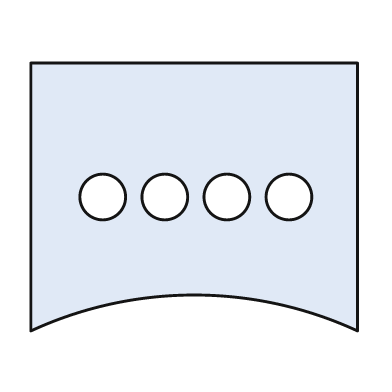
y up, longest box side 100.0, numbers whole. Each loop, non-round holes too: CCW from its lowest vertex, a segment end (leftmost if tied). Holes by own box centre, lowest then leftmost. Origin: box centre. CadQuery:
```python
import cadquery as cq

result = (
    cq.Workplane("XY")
    .moveTo(-50.0, -41.0)
    .threePointArc((0.0, -30.0), (50.0, -41.0))
    .lineTo(50.0, 41.0)
    .lineTo(-50.0, 41.0)
    .close()
    .moveTo(-28.0, 0.0)
    .circle(7.0)
    .moveTo(-9.0, 0.0)
    .circle(7.0)
    .moveTo(10.0, 0.0)
    .circle(7.0)
    .moveTo(29.0, 0.0)
    .circle(7.0)
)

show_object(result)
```